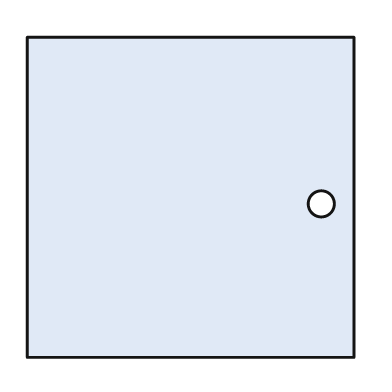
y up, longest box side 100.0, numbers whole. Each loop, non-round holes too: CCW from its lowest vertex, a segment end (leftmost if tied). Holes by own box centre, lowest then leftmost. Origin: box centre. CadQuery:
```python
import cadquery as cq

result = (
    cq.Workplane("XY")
    .moveTo(-50.0, -49.0)
    .lineTo(50.0, -49.0)
    .lineTo(50.0, 49.0)
    .lineTo(-50.0, 49.0)
    .close()
    .moveTo(40.0, -2.0)
    .circle(4.0)
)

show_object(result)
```